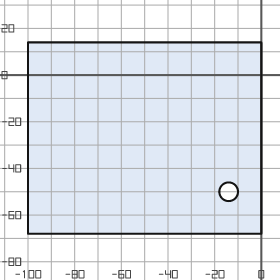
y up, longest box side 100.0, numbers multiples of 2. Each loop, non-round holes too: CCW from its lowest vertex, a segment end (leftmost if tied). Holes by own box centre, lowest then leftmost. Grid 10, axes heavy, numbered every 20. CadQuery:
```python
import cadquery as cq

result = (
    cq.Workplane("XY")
    .moveTo(-100.0, -68.0)
    .lineTo(0.0, -68.0)
    .lineTo(0.0, 14.0)
    .lineTo(-100.0, 14.0)
    .close()
    .moveTo(-14.0, -50.0)
    .circle(4.0)
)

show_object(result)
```